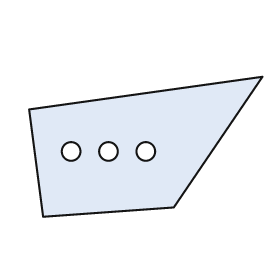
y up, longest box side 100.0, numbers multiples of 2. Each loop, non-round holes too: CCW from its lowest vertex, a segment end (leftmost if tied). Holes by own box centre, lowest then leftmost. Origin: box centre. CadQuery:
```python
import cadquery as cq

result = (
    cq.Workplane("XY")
    .moveTo(-44.0, -30.0)
    .lineTo(12.0, -26.0)
    .lineTo(50.0, 30.0)
    .lineTo(-50.0, 16.0)
    .close()
    .moveTo(-32.0, -2.0)
    .circle(4.0)
    .moveTo(-16.0, -2.0)
    .circle(4.0)
    .moveTo(0.0, -2.0)
    .circle(4.0)
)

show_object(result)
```